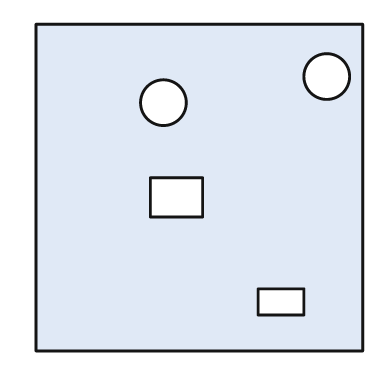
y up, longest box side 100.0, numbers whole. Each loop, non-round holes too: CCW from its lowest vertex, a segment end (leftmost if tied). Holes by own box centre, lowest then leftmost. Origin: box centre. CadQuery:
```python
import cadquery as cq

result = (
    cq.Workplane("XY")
    .moveTo(-50.0, -50.0)
    .lineTo(50.0, -50.0)
    .lineTo(50.0, 50.0)
    .lineTo(-50.0, 50.0)
    .close()
    .moveTo(18.0, -39.0)
    .lineTo(32.0, -39.0)
    .lineTo(32.0, -31.0)
    .lineTo(18.0, -31.0)
    .close()
    .moveTo(-15.0, -9.0)
    .lineTo(1.0, -9.0)
    .lineTo(1.0, 3.0)
    .lineTo(-15.0, 3.0)
    .close()
    .moveTo(-11.0, 26.0)
    .circle(7.0)
    .moveTo(39.0, 34.0)
    .circle(7.0)
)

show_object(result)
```